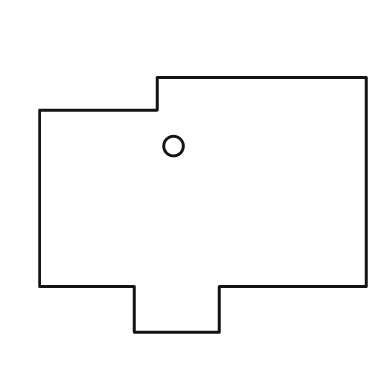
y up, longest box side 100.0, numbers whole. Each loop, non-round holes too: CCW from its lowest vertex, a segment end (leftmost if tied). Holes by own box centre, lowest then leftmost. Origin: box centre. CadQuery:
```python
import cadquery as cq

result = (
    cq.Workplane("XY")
    .moveTo(-21.0, -39.0)
    .lineTo(5.0, -39.0)
    .lineTo(5.0, -25.0)
    .lineTo(50.0, -25.0)
    .lineTo(50.0, 39.0)
    .lineTo(-14.0, 39.0)
    .lineTo(-14.0, 29.0)
    .lineTo(-50.0, 29.0)
    .lineTo(-50.0, -25.0)
    .lineTo(-21.0, -25.0)
    .close()
    .moveTo(-9.0, 18.0)
    .circle(3.0)
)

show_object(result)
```